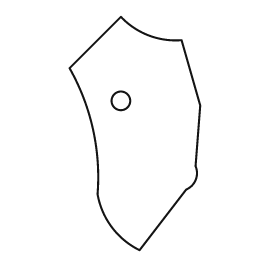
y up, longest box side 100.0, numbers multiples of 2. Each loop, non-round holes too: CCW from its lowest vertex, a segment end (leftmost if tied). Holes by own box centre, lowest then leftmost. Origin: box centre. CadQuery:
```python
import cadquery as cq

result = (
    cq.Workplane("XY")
    .moveTo(2.0, -50.0)
    .lineTo(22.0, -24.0)
    .threePointArc((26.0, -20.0), (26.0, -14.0))
    .lineTo(28.0, 12.0)
    .lineTo(20.0, 40.0)
    .threePointArc((6.0, 42.0), (-6.0, 50.0))
    .lineTo(-28.0, 28.0)
    .threePointArc((-18.0, 2.0), (-16.0, -26.0))
    .threePointArc((-10.0, -40.0), (2.0, -50.0))
    .close()
    .moveTo(-6.0, 14.0)
    .circle(4.0)
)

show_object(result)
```